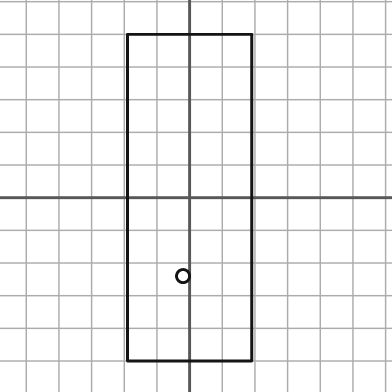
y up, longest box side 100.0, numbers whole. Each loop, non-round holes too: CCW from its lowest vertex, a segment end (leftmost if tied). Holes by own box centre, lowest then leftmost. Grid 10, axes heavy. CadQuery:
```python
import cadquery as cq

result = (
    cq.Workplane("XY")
    .moveTo(-19.0, -50.0)
    .lineTo(19.0, -50.0)
    .lineTo(19.0, 50.0)
    .lineTo(-19.0, 50.0)
    .close()
    .moveTo(-2.0, -24.0)
    .circle(2.0)
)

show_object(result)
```